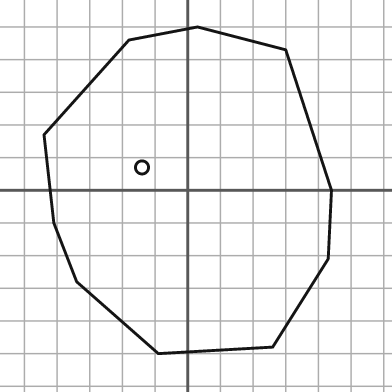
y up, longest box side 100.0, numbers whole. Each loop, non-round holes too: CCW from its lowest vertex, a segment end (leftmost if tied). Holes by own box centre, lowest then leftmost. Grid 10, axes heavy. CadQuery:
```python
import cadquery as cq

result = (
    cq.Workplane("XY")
    .moveTo(-9.0, -50.0)
    .lineTo(26.0, -48.0)
    .lineTo(43.0, -21.0)
    .lineTo(44.0, 0.0)
    .lineTo(30.0, 43.0)
    .lineTo(3.0, 50.0)
    .lineTo(-18.0, 46.0)
    .lineTo(-44.0, 17.0)
    .lineTo(-41.0, -10.0)
    .lineTo(-34.0, -28.0)
    .close()
    .moveTo(-14.0, 7.0)
    .circle(2.0)
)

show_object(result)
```